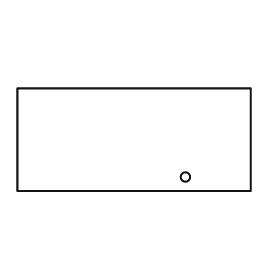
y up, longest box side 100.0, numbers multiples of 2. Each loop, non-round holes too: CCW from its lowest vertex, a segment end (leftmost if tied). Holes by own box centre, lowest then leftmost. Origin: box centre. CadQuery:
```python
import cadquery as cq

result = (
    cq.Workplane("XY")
    .moveTo(-50.0, -22.0)
    .lineTo(50.0, -22.0)
    .lineTo(50.0, 22.0)
    .lineTo(-50.0, 22.0)
    .close()
    .moveTo(22.0, -16.0)
    .circle(2.0)
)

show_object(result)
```